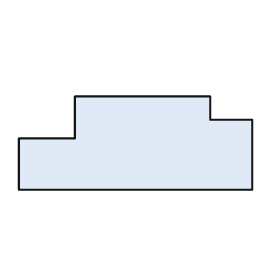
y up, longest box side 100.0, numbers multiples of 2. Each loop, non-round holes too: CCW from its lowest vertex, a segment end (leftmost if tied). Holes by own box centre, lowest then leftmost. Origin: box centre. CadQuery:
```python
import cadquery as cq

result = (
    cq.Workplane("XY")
    .moveTo(-50.0, -20.0)
    .lineTo(50.0, -20.0)
    .lineTo(50.0, 10.0)
    .lineTo(32.0, 10.0)
    .lineTo(32.0, 20.0)
    .lineTo(-26.0, 20.0)
    .lineTo(-26.0, 2.0)
    .lineTo(-50.0, 2.0)
    .close()
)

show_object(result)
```